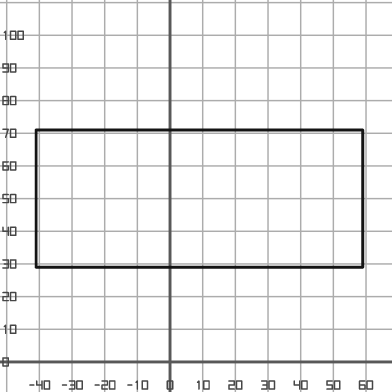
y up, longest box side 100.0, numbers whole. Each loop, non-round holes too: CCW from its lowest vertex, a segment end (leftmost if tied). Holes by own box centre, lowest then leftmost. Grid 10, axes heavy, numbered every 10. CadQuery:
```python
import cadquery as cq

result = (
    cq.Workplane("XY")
    .moveTo(-41.0, 29.0)
    .lineTo(59.0, 29.0)
    .lineTo(59.0, 71.0)
    .lineTo(-41.0, 71.0)
    .close()
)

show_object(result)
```